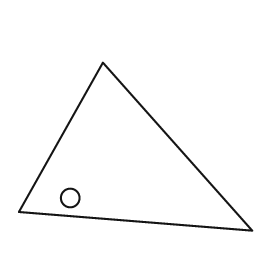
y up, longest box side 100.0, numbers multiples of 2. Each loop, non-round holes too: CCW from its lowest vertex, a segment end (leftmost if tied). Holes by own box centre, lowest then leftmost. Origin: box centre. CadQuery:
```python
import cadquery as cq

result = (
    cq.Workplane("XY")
    .moveTo(50.0, -36.0)
    .lineTo(-14.0, 36.0)
    .lineTo(-50.0, -28.0)
    .close()
    .moveTo(-28.0, -22.0)
    .circle(4.0)
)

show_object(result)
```